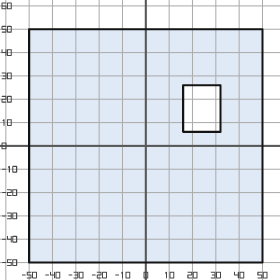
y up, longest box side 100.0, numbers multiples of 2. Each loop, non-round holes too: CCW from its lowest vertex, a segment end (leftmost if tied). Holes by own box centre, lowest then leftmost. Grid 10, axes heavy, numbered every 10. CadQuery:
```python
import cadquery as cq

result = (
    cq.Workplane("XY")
    .moveTo(-50.0, -50.0)
    .lineTo(50.0, -50.0)
    .lineTo(50.0, 50.0)
    .lineTo(-50.0, 50.0)
    .close()
    .moveTo(16.0, 6.0)
    .lineTo(32.0, 6.0)
    .lineTo(32.0, 26.0)
    .lineTo(16.0, 26.0)
    .close()
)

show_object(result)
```